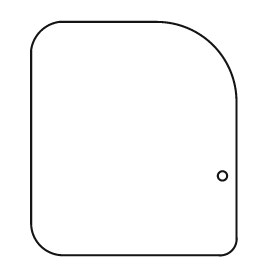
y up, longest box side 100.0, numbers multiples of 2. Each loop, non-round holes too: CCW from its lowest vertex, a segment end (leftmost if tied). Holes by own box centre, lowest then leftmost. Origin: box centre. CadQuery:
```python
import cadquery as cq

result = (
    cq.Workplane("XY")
    .moveTo(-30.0, -50.0)
    .lineTo(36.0, -50.0)
    .threePointArc((42.0, -48.0), (44.0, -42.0))
    .lineTo(44.0, 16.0)
    .threePointArc((34.0, 40.0), (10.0, 50.0))
    .lineTo(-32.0, 50.0)
    .threePointArc((-40.0, 46.0), (-44.0, 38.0))
    .lineTo(-44.0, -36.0)
    .threePointArc((-40.0, -46.0), (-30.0, -50.0))
    .close()
    .moveTo(38.0, -16.0)
    .circle(2.0)
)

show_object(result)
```